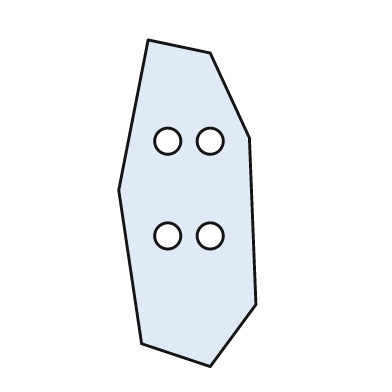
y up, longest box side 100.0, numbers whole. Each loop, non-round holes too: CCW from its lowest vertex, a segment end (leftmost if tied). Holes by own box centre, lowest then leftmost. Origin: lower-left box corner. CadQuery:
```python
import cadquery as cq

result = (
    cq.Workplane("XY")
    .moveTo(28.0, 0.0)
    .lineTo(42.0, 19.0)
    .lineTo(40.0, 70.0)
    .lineTo(28.0, 96.0)
    .lineTo(9.0, 100.0)
    .lineTo(0.0, 54.0)
    .lineTo(7.0, 7.0)
    .close()
    .moveTo(15.0, 40.0)
    .circle(4.0)
    .moveTo(28.0, 40.0)
    .circle(4.0)
    .moveTo(15.0, 69.0)
    .circle(4.0)
    .moveTo(28.0, 69.0)
    .circle(4.0)
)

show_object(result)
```